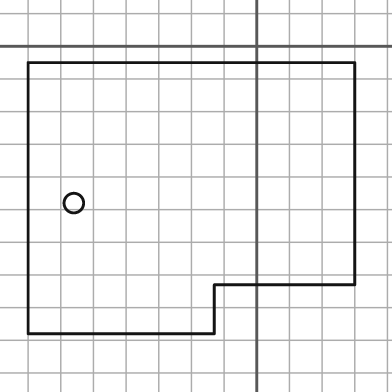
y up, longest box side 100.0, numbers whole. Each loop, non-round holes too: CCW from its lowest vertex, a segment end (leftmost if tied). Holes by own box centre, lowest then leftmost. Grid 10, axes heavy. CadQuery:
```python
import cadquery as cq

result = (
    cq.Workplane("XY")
    .moveTo(-70.0, -88.0)
    .lineTo(-13.0, -88.0)
    .lineTo(-13.0, -73.0)
    .lineTo(30.0, -73.0)
    .lineTo(30.0, -5.0)
    .lineTo(-70.0, -5.0)
    .close()
    .moveTo(-56.0, -48.0)
    .circle(3.0)
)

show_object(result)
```